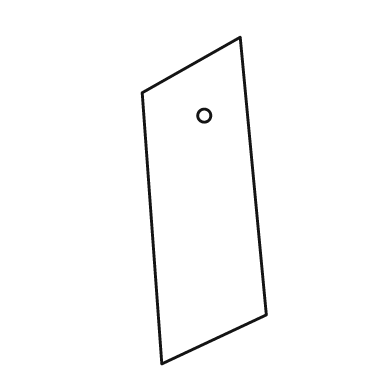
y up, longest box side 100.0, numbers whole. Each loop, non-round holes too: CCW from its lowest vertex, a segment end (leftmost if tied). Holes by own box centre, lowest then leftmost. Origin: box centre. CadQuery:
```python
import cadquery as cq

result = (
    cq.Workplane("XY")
    .moveTo(-13.0, -50.0)
    .lineTo(19.0, -35.0)
    .lineTo(11.0, 50.0)
    .lineTo(-19.0, 33.0)
    .close()
    .moveTo(0.0, 26.0)
    .circle(2.0)
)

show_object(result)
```